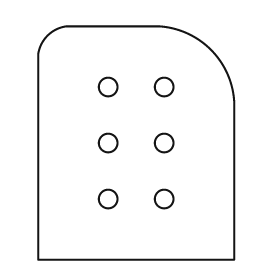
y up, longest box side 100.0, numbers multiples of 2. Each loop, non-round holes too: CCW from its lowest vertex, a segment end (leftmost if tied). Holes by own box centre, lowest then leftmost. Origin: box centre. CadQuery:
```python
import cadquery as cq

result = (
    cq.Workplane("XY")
    .moveTo(-42.0, -50.0)
    .lineTo(42.0, -50.0)
    .lineTo(42.0, 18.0)
    .threePointArc((32.0, 40.0), (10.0, 50.0))
    .lineTo(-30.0, 50.0)
    .threePointArc((-38.0, 46.0), (-42.0, 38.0))
    .close()
    .moveTo(-12.0, -24.0)
    .circle(4.0)
    .moveTo(12.0, -24.0)
    .circle(4.0)
    .moveTo(-12.0, 0.0)
    .circle(4.0)
    .moveTo(12.0, 0.0)
    .circle(4.0)
    .moveTo(-12.0, 24.0)
    .circle(4.0)
    .moveTo(12.0, 24.0)
    .circle(4.0)
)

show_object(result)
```